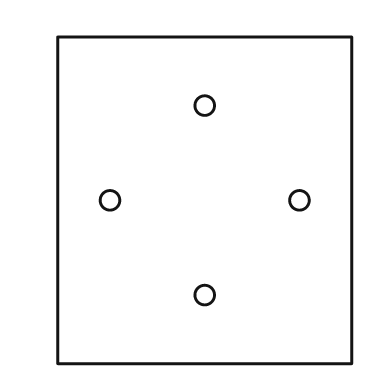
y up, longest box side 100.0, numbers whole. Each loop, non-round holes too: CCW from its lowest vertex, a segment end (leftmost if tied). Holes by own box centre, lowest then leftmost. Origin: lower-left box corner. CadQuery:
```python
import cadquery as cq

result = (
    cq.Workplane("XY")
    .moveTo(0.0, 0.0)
    .lineTo(90.0, 0.0)
    .lineTo(90.0, 100.0)
    .lineTo(0.0, 100.0)
    .close()
    .moveTo(45.0, 21.0)
    .circle(3.0)
    .moveTo(16.0, 50.0)
    .circle(3.0)
    .moveTo(74.0, 50.0)
    .circle(3.0)
    .moveTo(45.0, 79.0)
    .circle(3.0)
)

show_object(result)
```